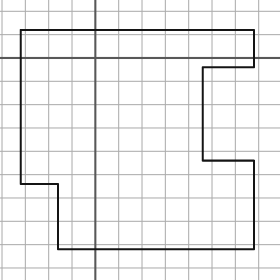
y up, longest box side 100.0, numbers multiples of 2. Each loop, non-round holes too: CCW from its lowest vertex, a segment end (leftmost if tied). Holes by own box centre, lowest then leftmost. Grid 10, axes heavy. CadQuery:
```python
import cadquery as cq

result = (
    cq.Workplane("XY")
    .moveTo(-16.0, -82.0)
    .lineTo(68.0, -82.0)
    .lineTo(68.0, -44.0)
    .lineTo(46.0, -44.0)
    .lineTo(46.0, -4.0)
    .lineTo(68.0, -4.0)
    .lineTo(68.0, 12.0)
    .lineTo(-32.0, 12.0)
    .lineTo(-32.0, -54.0)
    .lineTo(-16.0, -54.0)
    .close()
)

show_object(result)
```